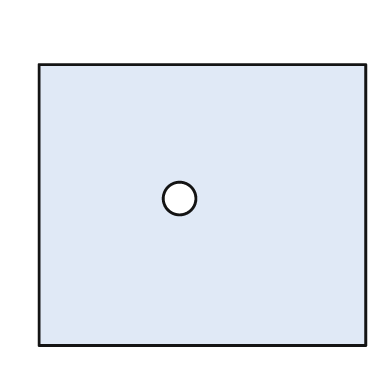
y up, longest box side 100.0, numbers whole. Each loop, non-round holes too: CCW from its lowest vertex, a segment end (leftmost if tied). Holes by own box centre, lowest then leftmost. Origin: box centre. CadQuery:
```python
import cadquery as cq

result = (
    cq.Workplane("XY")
    .moveTo(-50.0, -43.0)
    .lineTo(50.0, -43.0)
    .lineTo(50.0, 43.0)
    .lineTo(-50.0, 43.0)
    .close()
    .moveTo(-7.0, 2.0)
    .circle(5.0)
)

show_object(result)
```